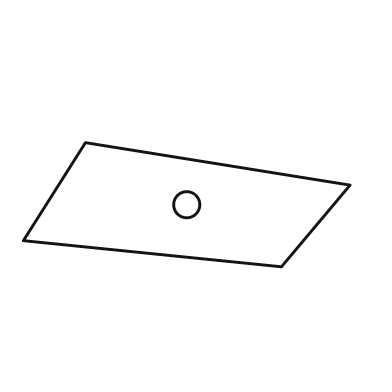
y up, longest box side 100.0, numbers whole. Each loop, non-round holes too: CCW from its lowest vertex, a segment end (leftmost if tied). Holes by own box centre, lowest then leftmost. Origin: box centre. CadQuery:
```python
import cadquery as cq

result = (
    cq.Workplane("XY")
    .moveTo(29.0, -19.0)
    .lineTo(50.0, 6.0)
    .lineTo(-31.0, 19.0)
    .lineTo(-50.0, -11.0)
    .close()
    .moveTo(0.0, 0.0)
    .circle(4.0)
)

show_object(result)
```